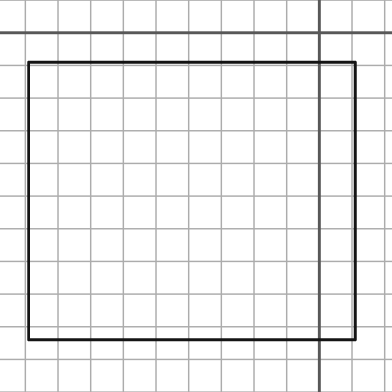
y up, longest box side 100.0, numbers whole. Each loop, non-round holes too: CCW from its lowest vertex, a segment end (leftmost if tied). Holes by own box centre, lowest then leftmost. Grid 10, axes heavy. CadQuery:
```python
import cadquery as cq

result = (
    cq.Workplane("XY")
    .moveTo(-89.0, -94.0)
    .lineTo(11.0, -94.0)
    .lineTo(11.0, -9.0)
    .lineTo(-89.0, -9.0)
    .close()
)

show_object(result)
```